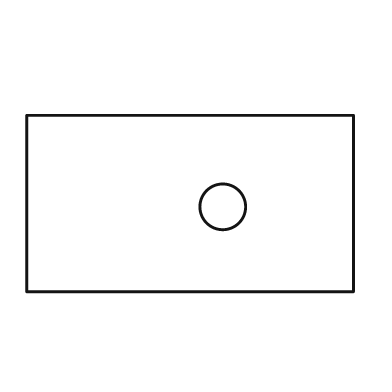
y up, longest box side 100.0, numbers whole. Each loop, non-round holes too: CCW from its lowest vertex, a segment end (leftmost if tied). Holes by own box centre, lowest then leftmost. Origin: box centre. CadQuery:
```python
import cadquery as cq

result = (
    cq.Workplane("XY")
    .moveTo(-50.0, -27.0)
    .lineTo(50.0, -27.0)
    .lineTo(50.0, 27.0)
    .lineTo(-50.0, 27.0)
    .close()
    .moveTo(10.0, -1.0)
    .circle(7.0)
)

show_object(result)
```